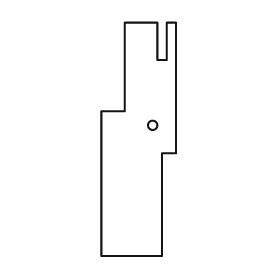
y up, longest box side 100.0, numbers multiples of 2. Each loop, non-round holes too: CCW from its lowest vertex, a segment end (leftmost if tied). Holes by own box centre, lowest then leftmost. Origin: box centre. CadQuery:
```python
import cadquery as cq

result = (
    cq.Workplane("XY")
    .moveTo(-16.0, -50.0)
    .lineTo(10.0, -50.0)
    .lineTo(10.0, -6.0)
    .lineTo(16.0, -6.0)
    .lineTo(16.0, 50.0)
    .lineTo(12.0, 50.0)
    .lineTo(12.0, 34.0)
    .lineTo(8.0, 34.0)
    .lineTo(8.0, 50.0)
    .lineTo(-6.0, 50.0)
    .lineTo(-6.0, 12.0)
    .lineTo(-16.0, 12.0)
    .close()
    .moveTo(6.0, 6.0)
    .circle(2.0)
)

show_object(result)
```